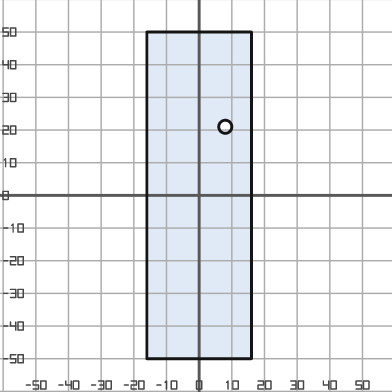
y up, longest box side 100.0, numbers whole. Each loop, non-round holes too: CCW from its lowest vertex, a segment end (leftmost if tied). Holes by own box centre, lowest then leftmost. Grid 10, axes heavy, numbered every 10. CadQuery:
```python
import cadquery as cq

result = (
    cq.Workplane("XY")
    .moveTo(-16.0, -50.0)
    .lineTo(16.0, -50.0)
    .lineTo(16.0, 50.0)
    .lineTo(-16.0, 50.0)
    .close()
    .moveTo(8.0, 21.0)
    .circle(2.0)
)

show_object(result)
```